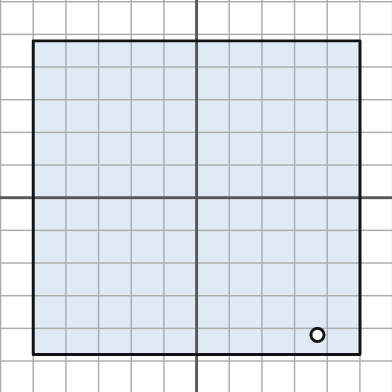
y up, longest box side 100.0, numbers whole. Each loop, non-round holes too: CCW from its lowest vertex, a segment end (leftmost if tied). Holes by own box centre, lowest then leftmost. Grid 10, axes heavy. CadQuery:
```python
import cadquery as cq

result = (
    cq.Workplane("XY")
    .moveTo(-50.0, -48.0)
    .lineTo(50.0, -48.0)
    .lineTo(50.0, 48.0)
    .lineTo(-50.0, 48.0)
    .close()
    .moveTo(37.0, -42.0)
    .circle(2.0)
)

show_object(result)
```